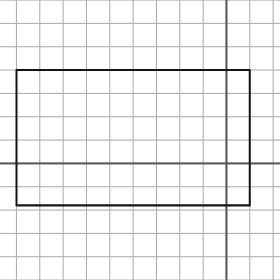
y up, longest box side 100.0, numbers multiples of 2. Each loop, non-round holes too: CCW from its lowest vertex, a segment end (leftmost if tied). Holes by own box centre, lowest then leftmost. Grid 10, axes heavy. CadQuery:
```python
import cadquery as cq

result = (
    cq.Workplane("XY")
    .moveTo(-90.0, -18.0)
    .lineTo(10.0, -18.0)
    .lineTo(10.0, 40.0)
    .lineTo(-90.0, 40.0)
    .close()
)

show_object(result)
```